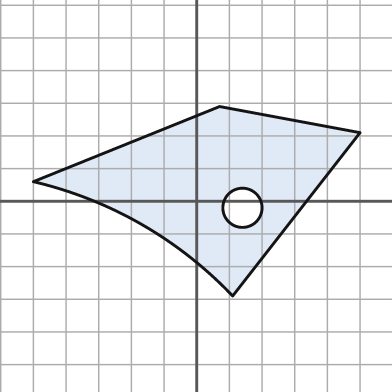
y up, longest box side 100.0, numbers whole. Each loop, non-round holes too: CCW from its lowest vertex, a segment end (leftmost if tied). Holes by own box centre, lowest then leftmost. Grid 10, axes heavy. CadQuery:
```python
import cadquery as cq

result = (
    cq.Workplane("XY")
    .moveTo(11.0, -29.0)
    .lineTo(50.0, 21.0)
    .lineTo(7.0, 29.0)
    .lineTo(-50.0, 6.0)
    .threePointArc((-17.0, -7.0), (11.0, -29.0))
    .close()
    .moveTo(14.0, -2.0)
    .circle(6.0)
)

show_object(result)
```